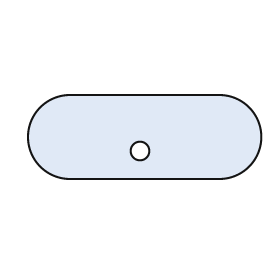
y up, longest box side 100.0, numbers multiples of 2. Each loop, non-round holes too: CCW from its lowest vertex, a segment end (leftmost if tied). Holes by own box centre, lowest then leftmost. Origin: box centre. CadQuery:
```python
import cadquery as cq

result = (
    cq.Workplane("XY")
    .moveTo(-32.0, -18.0)
    .lineTo(32.0, -18.0)
    .threePointArc((50.0, 0.0), (32.0, 18.0))
    .lineTo(-32.0, 18.0)
    .threePointArc((-50.0, 0.0), (-32.0, -18.0))
    .close()
    .moveTo(-2.0, -6.0)
    .circle(4.0)
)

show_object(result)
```